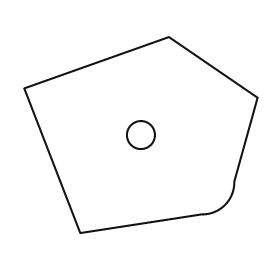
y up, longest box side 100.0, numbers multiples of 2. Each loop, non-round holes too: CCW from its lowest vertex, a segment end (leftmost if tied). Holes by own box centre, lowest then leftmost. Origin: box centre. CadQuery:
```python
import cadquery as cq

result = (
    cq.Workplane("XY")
    .moveTo(-26.0, -42.0)
    .lineTo(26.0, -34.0)
    .threePointArc((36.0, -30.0), (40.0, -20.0))
    .lineTo(50.0, 16.0)
    .lineTo(12.0, 42.0)
    .lineTo(-50.0, 20.0)
    .close()
    .moveTo(0.0, 0.0)
    .circle(6.0)
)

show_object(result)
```